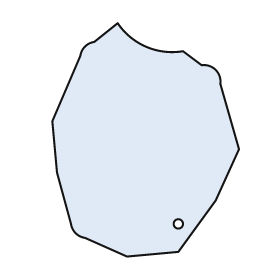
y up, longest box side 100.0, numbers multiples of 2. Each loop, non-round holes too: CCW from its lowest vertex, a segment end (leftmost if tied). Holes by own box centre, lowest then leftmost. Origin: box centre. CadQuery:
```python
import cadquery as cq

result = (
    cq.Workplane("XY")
    .moveTo(-8.0, -50.0)
    .lineTo(14.0, -48.0)
    .lineTo(30.0, -26.0)
    .lineTo(40.0, -4.0)
    .lineTo(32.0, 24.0)
    .threePointArc((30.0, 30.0), (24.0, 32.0))
    .lineTo(16.0, 38.0)
    .threePointArc((0.0, 40.0), (-12.0, 50.0))
    .lineTo(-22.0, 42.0)
    .threePointArc((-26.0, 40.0), (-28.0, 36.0))
    .lineTo(-40.0, 8.0)
    .lineTo(-38.0, -14.0)
    .lineTo(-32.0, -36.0)
    .threePointArc((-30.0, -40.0), (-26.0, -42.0))
    .close()
    .moveTo(14.0, -36.0)
    .circle(2.0)
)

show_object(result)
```